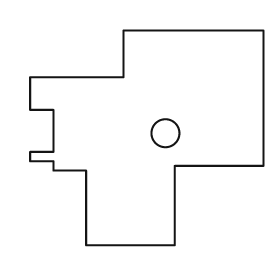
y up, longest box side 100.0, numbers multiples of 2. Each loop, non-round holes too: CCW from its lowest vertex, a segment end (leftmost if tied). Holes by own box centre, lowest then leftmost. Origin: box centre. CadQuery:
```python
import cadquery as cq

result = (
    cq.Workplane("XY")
    .moveTo(-26.0, -46.0)
    .lineTo(12.0, -46.0)
    .lineTo(12.0, -12.0)
    .lineTo(50.0, -12.0)
    .lineTo(50.0, 46.0)
    .lineTo(-10.0, 46.0)
    .lineTo(-10.0, 26.0)
    .lineTo(-50.0, 26.0)
    .lineTo(-50.0, 12.0)
    .lineTo(-40.0, 12.0)
    .lineTo(-40.0, -6.0)
    .lineTo(-50.0, -6.0)
    .lineTo(-50.0, -10.0)
    .lineTo(-40.0, -10.0)
    .lineTo(-40.0, -14.0)
    .lineTo(-26.0, -14.0)
    .close()
    .moveTo(8.0, 2.0)
    .circle(6.0)
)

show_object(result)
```